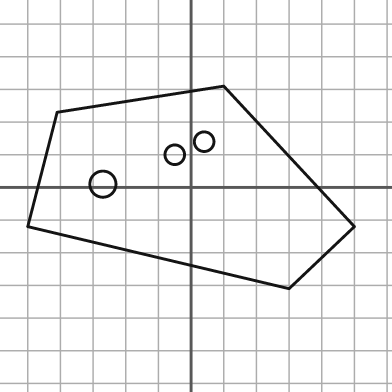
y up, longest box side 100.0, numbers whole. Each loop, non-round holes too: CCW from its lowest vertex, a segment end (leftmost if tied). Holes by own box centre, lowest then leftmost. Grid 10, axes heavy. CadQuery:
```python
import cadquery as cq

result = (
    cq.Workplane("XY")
    .moveTo(30.0, -31.0)
    .lineTo(50.0, -12.0)
    .lineTo(10.0, 31.0)
    .lineTo(-41.0, 23.0)
    .lineTo(-50.0, -12.0)
    .close()
    .moveTo(-27.0, 1.0)
    .circle(4.0)
    .moveTo(-5.0, 10.0)
    .circle(3.0)
    .moveTo(4.0, 14.0)
    .circle(3.0)
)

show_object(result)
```